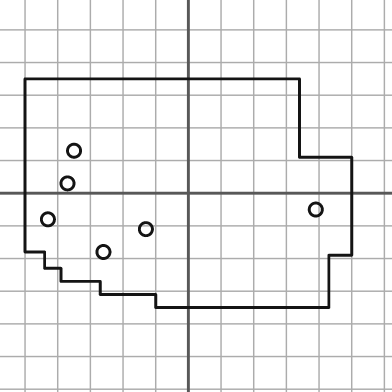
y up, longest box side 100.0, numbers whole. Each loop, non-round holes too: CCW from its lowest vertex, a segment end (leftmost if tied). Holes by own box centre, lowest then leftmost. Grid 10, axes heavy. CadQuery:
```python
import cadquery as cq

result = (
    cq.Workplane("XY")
    .moveTo(-10.0, -35.0)
    .lineTo(43.0, -35.0)
    .lineTo(43.0, -19.0)
    .lineTo(50.0, -19.0)
    .lineTo(50.0, 11.0)
    .lineTo(34.0, 11.0)
    .lineTo(34.0, 35.0)
    .lineTo(-50.0, 35.0)
    .lineTo(-50.0, -18.0)
    .lineTo(-44.0, -18.0)
    .lineTo(-44.0, -23.0)
    .lineTo(-39.0, -23.0)
    .lineTo(-39.0, -27.0)
    .lineTo(-27.0, -27.0)
    .lineTo(-27.0, -31.0)
    .lineTo(-10.0, -31.0)
    .close()
    .moveTo(-26.0, -18.0)
    .circle(2.0)
    .moveTo(-13.0, -11.0)
    .circle(2.0)
    .moveTo(-43.0, -8.0)
    .circle(2.0)
    .moveTo(39.0, -5.0)
    .circle(2.0)
    .moveTo(-37.0, 3.0)
    .circle(2.0)
    .moveTo(-35.0, 13.0)
    .circle(2.0)
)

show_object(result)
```